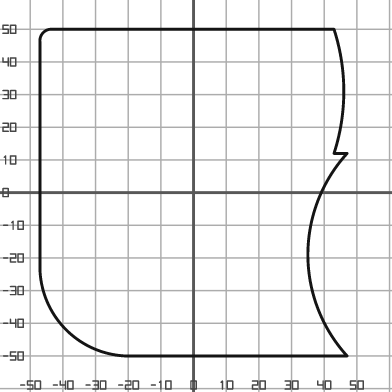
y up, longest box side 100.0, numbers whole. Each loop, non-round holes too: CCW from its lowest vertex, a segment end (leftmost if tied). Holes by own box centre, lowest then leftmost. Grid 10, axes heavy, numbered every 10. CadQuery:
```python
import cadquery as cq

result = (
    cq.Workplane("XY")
    .moveTo(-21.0, -50.0)
    .lineTo(47.0, -50.0)
    .threePointArc((35.0, -19.0), (47.0, 12.0))
    .lineTo(43.0, 12.0)
    .threePointArc((46.0, 31.0), (43.0, 50.0))
    .lineTo(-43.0, 50.0)
    .threePointArc((-46.0, 49.0), (-47.0, 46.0))
    .lineTo(-47.0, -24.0)
    .threePointArc((-39.0, -42.0), (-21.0, -50.0))
    .close()
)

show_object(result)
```